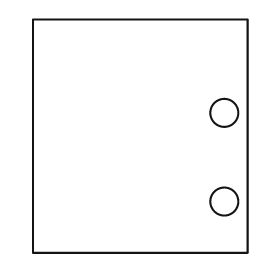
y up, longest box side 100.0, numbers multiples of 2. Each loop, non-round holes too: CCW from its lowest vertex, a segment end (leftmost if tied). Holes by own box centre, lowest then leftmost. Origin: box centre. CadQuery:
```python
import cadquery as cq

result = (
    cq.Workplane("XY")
    .moveTo(-46.0, -50.0)
    .lineTo(46.0, -50.0)
    .lineTo(46.0, 50.0)
    .lineTo(-46.0, 50.0)
    .close()
    .moveTo(36.0, -28.0)
    .circle(6.0)
    .moveTo(36.0, 10.0)
    .circle(6.0)
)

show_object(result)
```